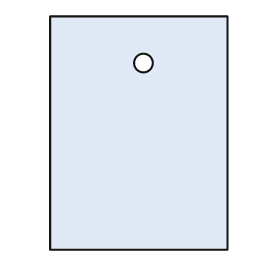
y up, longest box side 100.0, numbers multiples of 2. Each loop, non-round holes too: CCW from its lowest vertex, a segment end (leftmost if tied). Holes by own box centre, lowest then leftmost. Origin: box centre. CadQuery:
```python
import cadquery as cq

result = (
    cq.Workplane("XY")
    .moveTo(-38.0, -50.0)
    .lineTo(38.0, -50.0)
    .lineTo(38.0, 50.0)
    .lineTo(-38.0, 50.0)
    .close()
    .moveTo(2.0, 30.0)
    .circle(4.0)
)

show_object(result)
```